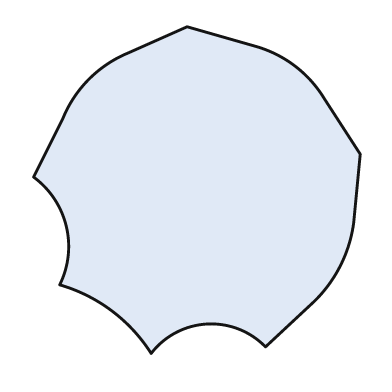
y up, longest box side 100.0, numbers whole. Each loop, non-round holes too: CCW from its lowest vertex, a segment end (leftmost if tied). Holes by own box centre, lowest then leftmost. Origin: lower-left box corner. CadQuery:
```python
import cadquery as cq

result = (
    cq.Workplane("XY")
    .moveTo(36.0, 0.0)
    .threePointArc((53.0, 9.0), (71.0, 2.0))
    .lineTo(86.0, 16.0)
    .threePointArc((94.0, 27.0), (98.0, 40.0))
    .lineTo(100.0, 61.0)
    .lineTo(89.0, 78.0)
    .threePointArc((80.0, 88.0), (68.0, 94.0))
    .lineTo(47.0, 100.0)
    .lineTo(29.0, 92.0)
    .threePointArc((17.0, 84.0), (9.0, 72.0))
    .lineTo(0.0, 54.0)
    .threePointArc((10.0, 39.0), (8.0, 21.0))
    .threePointArc((24.0, 13.0), (36.0, 0.0))
    .close()
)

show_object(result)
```